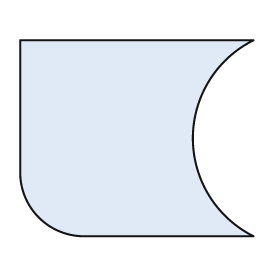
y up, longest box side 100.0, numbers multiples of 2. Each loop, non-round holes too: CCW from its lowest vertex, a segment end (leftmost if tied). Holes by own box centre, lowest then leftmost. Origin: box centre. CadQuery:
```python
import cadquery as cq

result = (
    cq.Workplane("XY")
    .moveTo(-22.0, -42.0)
    .lineTo(50.0, -42.0)
    .threePointArc((24.0, 0.0), (50.0, 42.0))
    .lineTo(-50.0, 42.0)
    .lineTo(-50.0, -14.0)
    .threePointArc((-42.0, -34.0), (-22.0, -42.0))
    .close()
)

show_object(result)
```